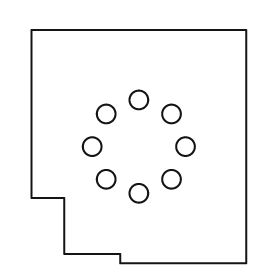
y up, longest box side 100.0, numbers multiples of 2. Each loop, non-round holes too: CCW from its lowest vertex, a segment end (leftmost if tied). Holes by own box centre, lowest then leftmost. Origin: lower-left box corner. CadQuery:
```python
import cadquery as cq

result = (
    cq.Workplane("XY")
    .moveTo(38.0, 0.0)
    .lineTo(92.0, 0.0)
    .lineTo(92.0, 100.0)
    .lineTo(0.0, 100.0)
    .lineTo(0.0, 28.0)
    .lineTo(14.0, 28.0)
    .lineTo(14.0, 4.0)
    .lineTo(38.0, 4.0)
    .close()
    .moveTo(46.0, 30.0)
    .circle(4.0)
    .moveTo(32.0, 36.0)
    .circle(4.0)
    .moveTo(60.0, 36.0)
    .circle(4.0)
    .moveTo(26.0, 50.0)
    .circle(4.0)
    .moveTo(66.0, 50.0)
    .circle(4.0)
    .moveTo(32.0, 64.0)
    .circle(4.0)
    .moveTo(60.0, 64.0)
    .circle(4.0)
    .moveTo(46.0, 70.0)
    .circle(4.0)
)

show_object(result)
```